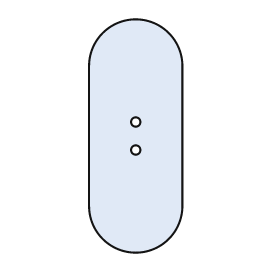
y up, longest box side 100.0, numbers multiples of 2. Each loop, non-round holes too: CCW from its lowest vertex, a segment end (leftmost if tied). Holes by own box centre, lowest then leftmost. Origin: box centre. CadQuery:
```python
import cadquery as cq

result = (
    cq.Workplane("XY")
    .moveTo(-20.0, -30.0)
    .threePointArc((0.0, -50.0), (20.0, -30.0))
    .lineTo(20.0, 30.0)
    .threePointArc((0.0, 50.0), (-20.0, 30.0))
    .close()
    .moveTo(0.0, -6.0)
    .circle(2.0)
    .moveTo(0.0, 6.0)
    .circle(2.0)
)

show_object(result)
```